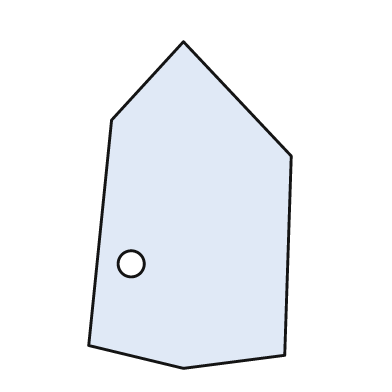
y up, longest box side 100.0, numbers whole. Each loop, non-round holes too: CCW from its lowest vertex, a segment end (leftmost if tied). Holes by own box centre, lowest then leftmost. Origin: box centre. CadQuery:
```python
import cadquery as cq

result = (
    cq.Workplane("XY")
    .moveTo(-2.0, -50.0)
    .lineTo(29.0, -46.0)
    .lineTo(31.0, 15.0)
    .lineTo(-2.0, 50.0)
    .lineTo(-24.0, 26.0)
    .lineTo(-31.0, -43.0)
    .close()
    .moveTo(-18.0, -18.0)
    .circle(4.0)
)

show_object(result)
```